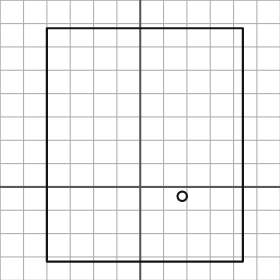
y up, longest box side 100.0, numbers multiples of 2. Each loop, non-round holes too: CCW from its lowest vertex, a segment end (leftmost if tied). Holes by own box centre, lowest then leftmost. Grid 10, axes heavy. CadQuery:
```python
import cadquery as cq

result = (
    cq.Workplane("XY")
    .moveTo(-40.0, -32.0)
    .lineTo(44.0, -32.0)
    .lineTo(44.0, 68.0)
    .lineTo(-40.0, 68.0)
    .close()
    .moveTo(18.0, -4.0)
    .circle(2.0)
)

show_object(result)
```